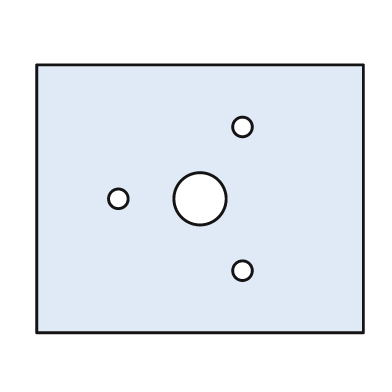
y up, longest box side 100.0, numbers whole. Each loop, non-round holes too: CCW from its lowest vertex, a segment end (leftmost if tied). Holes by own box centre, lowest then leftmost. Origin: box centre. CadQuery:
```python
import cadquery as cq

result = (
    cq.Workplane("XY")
    .moveTo(-50.0, -41.0)
    .lineTo(50.0, -41.0)
    .lineTo(50.0, 41.0)
    .lineTo(-50.0, 41.0)
    .close()
    .moveTo(13.0, -22.0)
    .circle(3.0)
    .moveTo(-25.0, 0.0)
    .circle(3.0)
    .moveTo(0.0, 0.0)
    .circle(8.0)
    .moveTo(13.0, 22.0)
    .circle(3.0)
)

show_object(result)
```